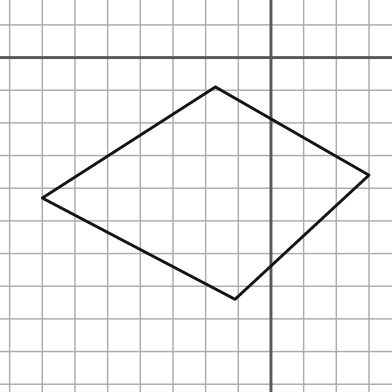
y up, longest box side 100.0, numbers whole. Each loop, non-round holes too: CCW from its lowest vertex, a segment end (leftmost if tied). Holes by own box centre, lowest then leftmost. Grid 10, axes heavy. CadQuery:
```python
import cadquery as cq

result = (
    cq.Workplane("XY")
    .moveTo(-11.0, -74.0)
    .lineTo(30.0, -36.0)
    .lineTo(-17.0, -9.0)
    .lineTo(-70.0, -43.0)
    .close()
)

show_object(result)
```